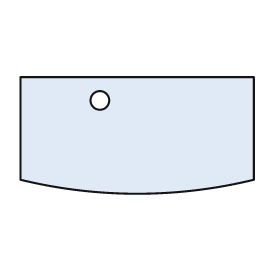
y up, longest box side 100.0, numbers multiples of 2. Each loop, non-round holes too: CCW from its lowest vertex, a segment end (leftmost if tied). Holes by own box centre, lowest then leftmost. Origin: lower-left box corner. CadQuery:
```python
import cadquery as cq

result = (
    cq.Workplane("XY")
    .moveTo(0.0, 6.0)
    .threePointArc((50.0, 0.0), (100.0, 6.0))
    .lineTo(100.0, 50.0)
    .lineTo(0.0, 50.0)
    .close()
    .moveTo(34.0, 40.0)
    .circle(4.0)
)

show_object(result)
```